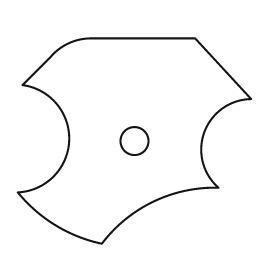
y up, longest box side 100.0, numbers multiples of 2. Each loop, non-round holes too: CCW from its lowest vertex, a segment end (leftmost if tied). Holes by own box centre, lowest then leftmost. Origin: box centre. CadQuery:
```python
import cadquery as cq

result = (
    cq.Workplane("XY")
    .moveTo(-14.0, -44.0)
    .threePointArc((8.0, -26.0), (36.0, -20.0))
    .threePointArc((30.0, 4.0), (50.0, 18.0))
    .lineTo(26.0, 44.0)
    .lineTo(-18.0, 44.0)
    .threePointArc((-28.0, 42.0), (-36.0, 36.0))
    .lineTo(-48.0, 24.0)
    .threePointArc((-28.0, 0.0), (-50.0, -22.0))
    .threePointArc((-34.0, -36.0), (-14.0, -44.0))
    .close()
    .moveTo(0.0, 0.0)
    .circle(6.0)
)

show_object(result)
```